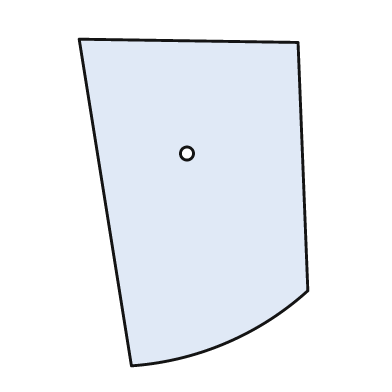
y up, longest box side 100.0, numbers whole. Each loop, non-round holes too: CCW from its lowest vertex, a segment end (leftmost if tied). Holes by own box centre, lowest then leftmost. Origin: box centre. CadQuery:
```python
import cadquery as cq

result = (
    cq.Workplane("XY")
    .moveTo(-19.0, -50.0)
    .threePointArc((10.0, -43.0), (35.0, -27.0))
    .lineTo(32.0, 49.0)
    .lineTo(-35.0, 50.0)
    .close()
    .moveTo(-2.0, 15.0)
    .circle(2.0)
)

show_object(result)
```